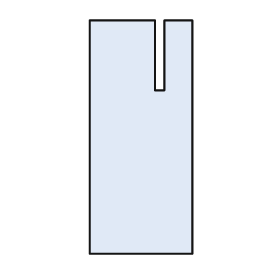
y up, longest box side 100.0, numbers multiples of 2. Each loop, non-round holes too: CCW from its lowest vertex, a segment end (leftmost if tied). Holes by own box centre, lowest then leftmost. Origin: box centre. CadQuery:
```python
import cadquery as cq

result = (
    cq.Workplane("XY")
    .moveTo(-22.0, -50.0)
    .lineTo(22.0, -50.0)
    .lineTo(22.0, 50.0)
    .lineTo(10.0, 50.0)
    .lineTo(10.0, 20.0)
    .lineTo(6.0, 20.0)
    .lineTo(6.0, 50.0)
    .lineTo(-22.0, 50.0)
    .close()
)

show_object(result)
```